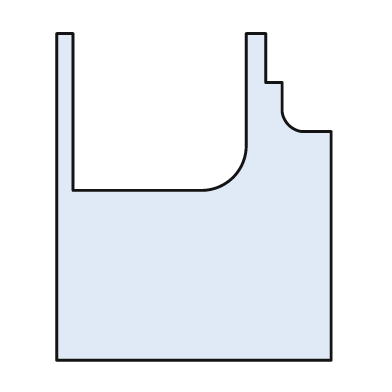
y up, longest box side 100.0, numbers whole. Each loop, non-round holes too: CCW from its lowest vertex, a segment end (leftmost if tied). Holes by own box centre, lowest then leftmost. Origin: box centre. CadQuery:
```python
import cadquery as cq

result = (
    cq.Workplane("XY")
    .moveTo(-42.0, -50.0)
    .lineTo(42.0, -50.0)
    .lineTo(42.0, 20.0)
    .lineTo(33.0, 20.0)
    .threePointArc((29.0, 22.0), (27.0, 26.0))
    .lineTo(27.0, 35.0)
    .lineTo(22.0, 35.0)
    .lineTo(22.0, 50.0)
    .lineTo(16.0, 50.0)
    .lineTo(16.0, 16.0)
    .threePointArc((12.0, 6.0), (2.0, 2.0))
    .lineTo(-37.0, 2.0)
    .lineTo(-37.0, 50.0)
    .lineTo(-42.0, 50.0)
    .close()
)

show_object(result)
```